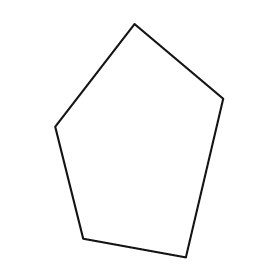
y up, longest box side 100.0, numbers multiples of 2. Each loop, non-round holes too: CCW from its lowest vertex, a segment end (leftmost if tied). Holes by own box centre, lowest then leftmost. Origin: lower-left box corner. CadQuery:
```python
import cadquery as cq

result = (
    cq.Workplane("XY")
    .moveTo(56.0, 0.0)
    .lineTo(72.0, 68.0)
    .lineTo(34.0, 100.0)
    .lineTo(0.0, 56.0)
    .lineTo(12.0, 8.0)
    .close()
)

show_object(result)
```